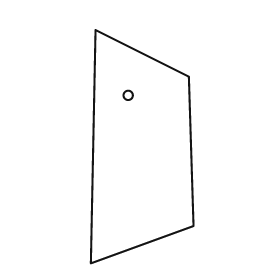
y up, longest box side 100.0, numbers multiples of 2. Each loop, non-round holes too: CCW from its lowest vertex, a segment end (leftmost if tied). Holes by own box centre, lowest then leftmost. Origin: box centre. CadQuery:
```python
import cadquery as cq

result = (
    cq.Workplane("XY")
    .moveTo(-22.0, -50.0)
    .lineTo(22.0, -34.0)
    .lineTo(20.0, 30.0)
    .lineTo(-20.0, 50.0)
    .close()
    .moveTo(-6.0, 22.0)
    .circle(2.0)
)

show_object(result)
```